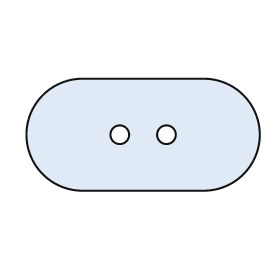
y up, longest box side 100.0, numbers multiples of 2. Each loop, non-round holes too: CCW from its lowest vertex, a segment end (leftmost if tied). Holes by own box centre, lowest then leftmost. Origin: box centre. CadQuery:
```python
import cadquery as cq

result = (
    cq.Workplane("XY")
    .moveTo(-26.0, -24.0)
    .lineTo(26.0, -24.0)
    .threePointArc((50.0, 0.0), (26.0, 24.0))
    .lineTo(-26.0, 24.0)
    .threePointArc((-50.0, 0.0), (-26.0, -24.0))
    .close()
    .moveTo(-10.0, 0.0)
    .circle(4.0)
    .moveTo(10.0, 0.0)
    .circle(4.0)
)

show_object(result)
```